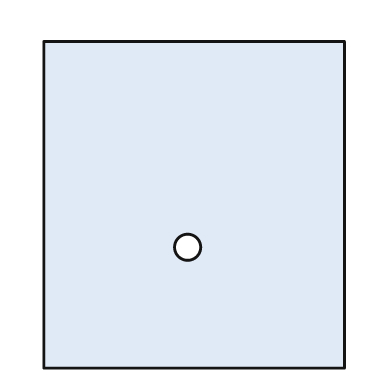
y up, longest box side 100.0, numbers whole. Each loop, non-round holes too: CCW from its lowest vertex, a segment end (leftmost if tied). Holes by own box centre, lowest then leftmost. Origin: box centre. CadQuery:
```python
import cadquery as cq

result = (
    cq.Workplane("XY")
    .moveTo(-46.0, -50.0)
    .lineTo(46.0, -50.0)
    .lineTo(46.0, 50.0)
    .lineTo(-46.0, 50.0)
    .close()
    .moveTo(-2.0, -13.0)
    .circle(4.0)
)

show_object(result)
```